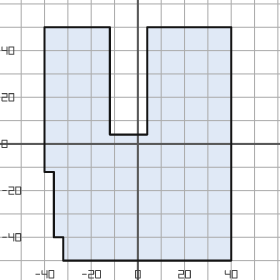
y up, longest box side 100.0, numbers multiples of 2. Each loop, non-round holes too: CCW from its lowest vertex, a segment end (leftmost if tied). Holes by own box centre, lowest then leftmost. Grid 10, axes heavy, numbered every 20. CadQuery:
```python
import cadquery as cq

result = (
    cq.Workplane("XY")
    .moveTo(-32.0, -50.0)
    .lineTo(40.0, -50.0)
    .lineTo(40.0, 50.0)
    .lineTo(4.0, 50.0)
    .lineTo(4.0, 4.0)
    .lineTo(-12.0, 4.0)
    .lineTo(-12.0, 50.0)
    .lineTo(-40.0, 50.0)
    .lineTo(-40.0, -12.0)
    .lineTo(-36.0, -12.0)
    .lineTo(-36.0, -40.0)
    .lineTo(-32.0, -40.0)
    .close()
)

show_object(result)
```